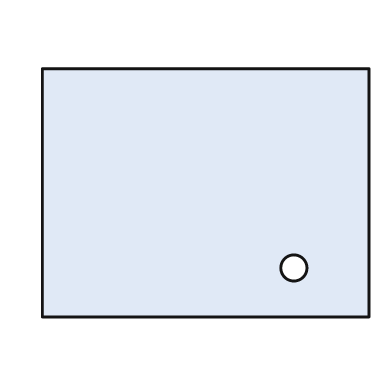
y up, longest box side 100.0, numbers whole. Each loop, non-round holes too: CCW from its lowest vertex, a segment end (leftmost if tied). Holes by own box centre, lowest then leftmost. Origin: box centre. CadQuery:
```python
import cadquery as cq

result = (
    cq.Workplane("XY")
    .moveTo(-50.0, -38.0)
    .lineTo(50.0, -38.0)
    .lineTo(50.0, 38.0)
    .lineTo(-50.0, 38.0)
    .close()
    .moveTo(27.0, -23.0)
    .circle(4.0)
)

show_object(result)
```